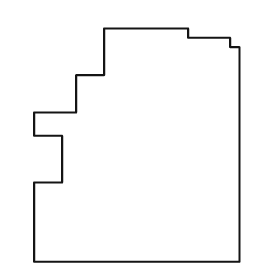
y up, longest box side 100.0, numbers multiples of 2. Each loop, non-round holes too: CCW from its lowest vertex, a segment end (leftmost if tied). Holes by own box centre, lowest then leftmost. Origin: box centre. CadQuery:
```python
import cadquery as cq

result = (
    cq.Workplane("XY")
    .moveTo(-44.0, -50.0)
    .lineTo(44.0, -50.0)
    .lineTo(44.0, 42.0)
    .lineTo(40.0, 42.0)
    .lineTo(40.0, 46.0)
    .lineTo(22.0, 46.0)
    .lineTo(22.0, 50.0)
    .lineTo(-14.0, 50.0)
    .lineTo(-14.0, 30.0)
    .lineTo(-26.0, 30.0)
    .lineTo(-26.0, 14.0)
    .lineTo(-44.0, 14.0)
    .lineTo(-44.0, 4.0)
    .lineTo(-32.0, 4.0)
    .lineTo(-32.0, -16.0)
    .lineTo(-44.0, -16.0)
    .close()
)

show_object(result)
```